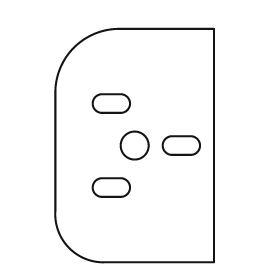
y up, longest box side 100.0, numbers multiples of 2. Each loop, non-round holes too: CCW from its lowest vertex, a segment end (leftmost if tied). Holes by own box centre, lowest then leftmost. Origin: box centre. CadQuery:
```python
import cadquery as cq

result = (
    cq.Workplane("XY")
    .moveTo(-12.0, -50.0)
    .lineTo(34.0, -50.0)
    .lineTo(34.0, 50.0)
    .lineTo(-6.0, 50.0)
    .threePointArc((-26.0, 42.0), (-34.0, 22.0))
    .lineTo(-34.0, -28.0)
    .threePointArc((-28.0, -44.0), (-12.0, -50.0))
    .close()
    .moveTo(-14.0, -22.0)
    .lineTo(-6.0, -22.0)
    .threePointArc((-2.0, -18.0), (-6.0, -14.0))
    .lineTo(-14.0, -14.0)
    .threePointArc((-18.0, -18.0), (-14.0, -22.0))
    .close()
    .moveTo(0.0, 0.0)
    .circle(6.0)
    .moveTo(16.0, -4.0)
    .lineTo(24.0, -4.0)
    .threePointArc((28.0, 0.0), (24.0, 4.0))
    .lineTo(16.0, 4.0)
    .threePointArc((12.0, 0.0), (16.0, -4.0))
    .close()
    .moveTo(-14.0, 14.0)
    .lineTo(-6.0, 14.0)
    .threePointArc((-2.0, 18.0), (-6.0, 22.0))
    .lineTo(-14.0, 22.0)
    .threePointArc((-18.0, 18.0), (-14.0, 14.0))
    .close()
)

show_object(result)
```